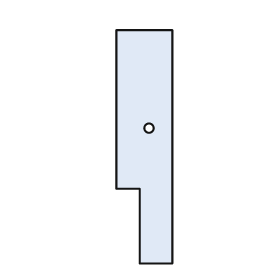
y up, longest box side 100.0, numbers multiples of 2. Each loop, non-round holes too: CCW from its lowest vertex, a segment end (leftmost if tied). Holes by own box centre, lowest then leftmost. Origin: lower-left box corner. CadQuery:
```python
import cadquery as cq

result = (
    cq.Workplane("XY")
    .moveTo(10.0, 0.0)
    .lineTo(24.0, 0.0)
    .lineTo(24.0, 100.0)
    .lineTo(0.0, 100.0)
    .lineTo(0.0, 32.0)
    .lineTo(10.0, 32.0)
    .close()
    .moveTo(14.0, 58.0)
    .circle(2.0)
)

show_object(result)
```